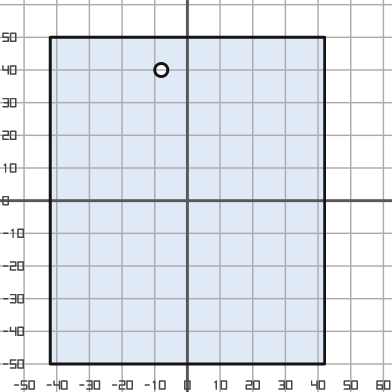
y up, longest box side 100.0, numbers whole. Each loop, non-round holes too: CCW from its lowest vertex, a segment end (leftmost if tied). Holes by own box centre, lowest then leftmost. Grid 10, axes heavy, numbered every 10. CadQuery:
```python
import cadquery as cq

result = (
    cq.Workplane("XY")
    .moveTo(-42.0, -50.0)
    .lineTo(42.0, -50.0)
    .lineTo(42.0, 50.0)
    .lineTo(-42.0, 50.0)
    .close()
    .moveTo(-8.0, 40.0)
    .circle(2.0)
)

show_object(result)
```